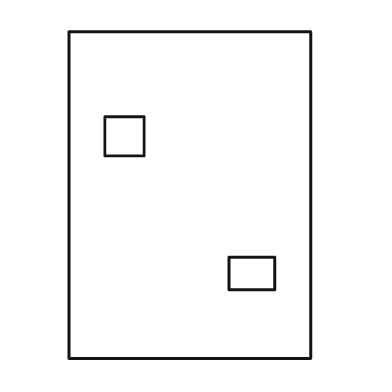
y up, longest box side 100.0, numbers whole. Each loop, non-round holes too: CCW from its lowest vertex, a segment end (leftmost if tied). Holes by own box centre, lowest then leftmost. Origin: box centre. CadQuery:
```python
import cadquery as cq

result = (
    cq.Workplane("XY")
    .moveTo(-37.0, -50.0)
    .lineTo(37.0, -50.0)
    .lineTo(37.0, 50.0)
    .lineTo(-37.0, 50.0)
    .close()
    .moveTo(12.0, -29.0)
    .lineTo(26.0, -29.0)
    .lineTo(26.0, -19.0)
    .lineTo(12.0, -19.0)
    .close()
    .moveTo(-26.0, 12.0)
    .lineTo(-14.0, 12.0)
    .lineTo(-14.0, 24.0)
    .lineTo(-26.0, 24.0)
    .close()
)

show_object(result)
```